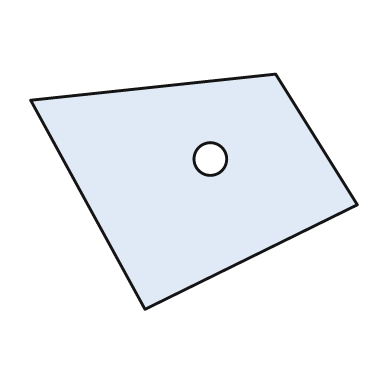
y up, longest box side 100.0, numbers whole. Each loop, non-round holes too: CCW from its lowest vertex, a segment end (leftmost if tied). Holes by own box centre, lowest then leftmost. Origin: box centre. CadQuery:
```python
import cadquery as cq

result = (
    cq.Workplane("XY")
    .moveTo(-15.0, -36.0)
    .lineTo(50.0, -4.0)
    .lineTo(25.0, 36.0)
    .lineTo(-50.0, 28.0)
    .close()
    .moveTo(5.0, 10.0)
    .circle(5.0)
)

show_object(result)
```